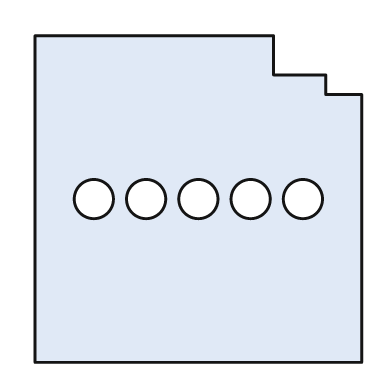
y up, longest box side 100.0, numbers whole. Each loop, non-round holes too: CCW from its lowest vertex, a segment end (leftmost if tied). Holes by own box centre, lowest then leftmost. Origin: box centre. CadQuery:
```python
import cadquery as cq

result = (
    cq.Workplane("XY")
    .moveTo(-50.0, -50.0)
    .lineTo(50.0, -50.0)
    .lineTo(50.0, 32.0)
    .lineTo(39.0, 32.0)
    .lineTo(39.0, 38.0)
    .lineTo(23.0, 38.0)
    .lineTo(23.0, 50.0)
    .lineTo(-50.0, 50.0)
    .close()
    .moveTo(-32.0, 0.0)
    .circle(6.0)
    .moveTo(-16.0, 0.0)
    .circle(6.0)
    .moveTo(0.0, 0.0)
    .circle(6.0)
    .moveTo(16.0, 0.0)
    .circle(6.0)
    .moveTo(32.0, 0.0)
    .circle(6.0)
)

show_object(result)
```